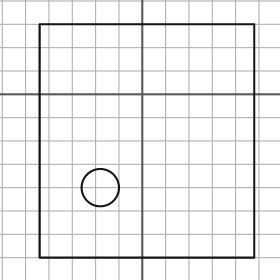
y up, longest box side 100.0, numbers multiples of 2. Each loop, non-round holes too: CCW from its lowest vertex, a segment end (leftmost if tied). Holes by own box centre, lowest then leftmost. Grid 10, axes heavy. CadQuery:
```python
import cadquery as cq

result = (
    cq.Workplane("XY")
    .moveTo(-44.0, -70.0)
    .lineTo(48.0, -70.0)
    .lineTo(48.0, 30.0)
    .lineTo(-44.0, 30.0)
    .close()
    .moveTo(-18.0, -40.0)
    .circle(8.0)
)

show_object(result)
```